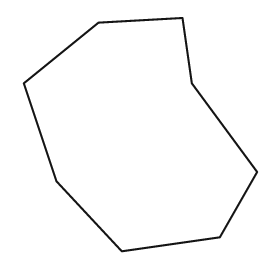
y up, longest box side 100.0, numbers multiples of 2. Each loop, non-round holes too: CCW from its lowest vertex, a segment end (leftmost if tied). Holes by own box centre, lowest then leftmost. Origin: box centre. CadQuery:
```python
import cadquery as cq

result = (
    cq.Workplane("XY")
    .moveTo(-8.0, -50.0)
    .lineTo(34.0, -44.0)
    .lineTo(50.0, -16.0)
    .lineTo(22.0, 22.0)
    .lineTo(18.0, 50.0)
    .lineTo(-18.0, 48.0)
    .lineTo(-50.0, 22.0)
    .lineTo(-36.0, -20.0)
    .close()
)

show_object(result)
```